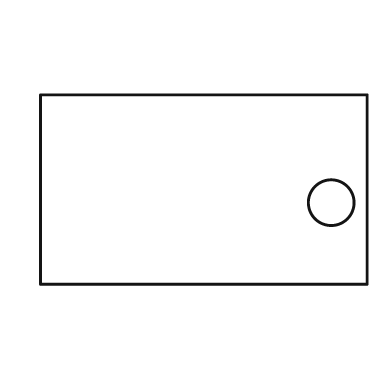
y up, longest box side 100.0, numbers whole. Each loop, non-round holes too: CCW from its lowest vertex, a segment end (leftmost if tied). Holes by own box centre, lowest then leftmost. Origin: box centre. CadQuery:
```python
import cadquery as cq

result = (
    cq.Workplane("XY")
    .moveTo(-50.0, -29.0)
    .lineTo(50.0, -29.0)
    .lineTo(50.0, 29.0)
    .lineTo(-50.0, 29.0)
    .close()
    .moveTo(39.0, -4.0)
    .circle(7.0)
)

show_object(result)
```